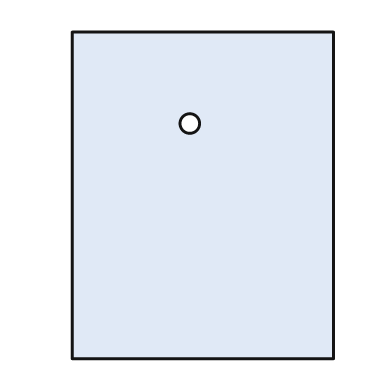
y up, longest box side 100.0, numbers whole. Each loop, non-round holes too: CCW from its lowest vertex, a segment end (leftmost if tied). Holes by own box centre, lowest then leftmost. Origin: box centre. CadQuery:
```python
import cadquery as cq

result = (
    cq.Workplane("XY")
    .moveTo(-40.0, -50.0)
    .lineTo(40.0, -50.0)
    .lineTo(40.0, 50.0)
    .lineTo(-40.0, 50.0)
    .close()
    .moveTo(-4.0, 22.0)
    .circle(3.0)
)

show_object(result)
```